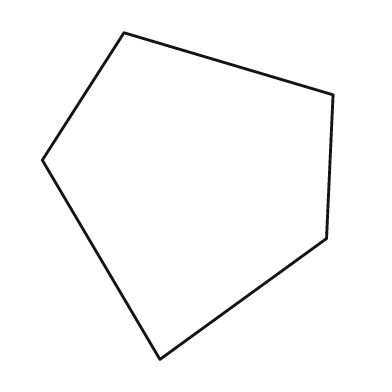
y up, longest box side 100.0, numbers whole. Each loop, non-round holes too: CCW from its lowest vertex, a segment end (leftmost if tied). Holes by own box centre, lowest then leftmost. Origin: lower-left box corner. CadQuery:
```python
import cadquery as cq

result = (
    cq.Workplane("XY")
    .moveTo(36.0, 0.0)
    .lineTo(87.0, 37.0)
    .lineTo(89.0, 81.0)
    .lineTo(25.0, 100.0)
    .lineTo(0.0, 61.0)
    .close()
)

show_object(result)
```